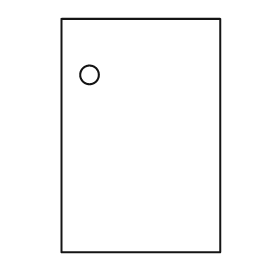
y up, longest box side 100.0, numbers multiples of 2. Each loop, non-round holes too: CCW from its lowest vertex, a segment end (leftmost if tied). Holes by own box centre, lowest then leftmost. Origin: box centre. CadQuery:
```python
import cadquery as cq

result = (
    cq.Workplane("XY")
    .moveTo(-34.0, -50.0)
    .lineTo(34.0, -50.0)
    .lineTo(34.0, 50.0)
    .lineTo(-34.0, 50.0)
    .close()
    .moveTo(-22.0, 26.0)
    .circle(4.0)
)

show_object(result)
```